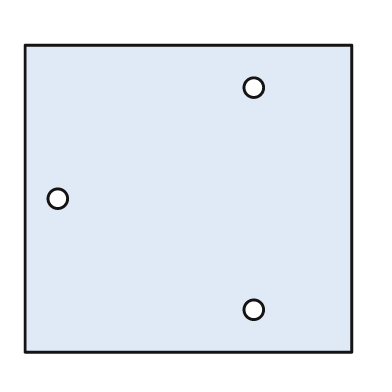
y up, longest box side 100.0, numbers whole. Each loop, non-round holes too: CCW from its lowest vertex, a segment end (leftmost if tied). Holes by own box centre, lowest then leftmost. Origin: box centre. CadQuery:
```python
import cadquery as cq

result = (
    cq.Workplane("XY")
    .moveTo(-50.0, -47.0)
    .lineTo(50.0, -47.0)
    .lineTo(50.0, 47.0)
    .lineTo(-50.0, 47.0)
    .close()
    .moveTo(20.0, -34.0)
    .circle(3.0)
    .moveTo(-40.0, 0.0)
    .circle(3.0)
    .moveTo(20.0, 34.0)
    .circle(3.0)
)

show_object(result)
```